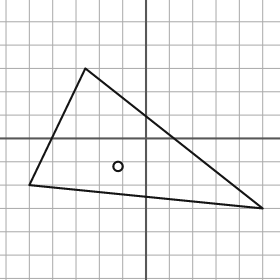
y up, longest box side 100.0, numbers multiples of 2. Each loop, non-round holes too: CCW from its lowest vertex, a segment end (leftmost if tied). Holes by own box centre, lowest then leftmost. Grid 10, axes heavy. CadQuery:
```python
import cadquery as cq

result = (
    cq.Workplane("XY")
    .moveTo(50.0, -30.0)
    .lineTo(-26.0, 30.0)
    .lineTo(-50.0, -20.0)
    .close()
    .moveTo(-12.0, -12.0)
    .circle(2.0)
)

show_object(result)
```